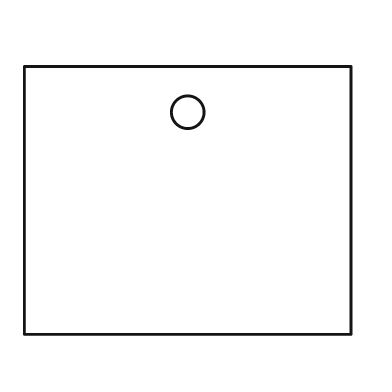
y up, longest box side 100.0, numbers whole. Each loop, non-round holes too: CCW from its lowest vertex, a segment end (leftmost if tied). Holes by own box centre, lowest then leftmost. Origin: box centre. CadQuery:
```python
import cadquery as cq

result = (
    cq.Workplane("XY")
    .moveTo(-50.0, -41.0)
    .lineTo(50.0, -41.0)
    .lineTo(50.0, 41.0)
    .lineTo(-50.0, 41.0)
    .close()
    .moveTo(0.0, 27.0)
    .circle(5.0)
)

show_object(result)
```